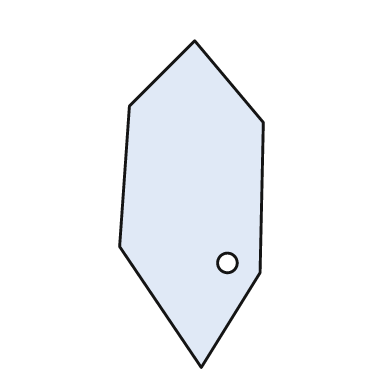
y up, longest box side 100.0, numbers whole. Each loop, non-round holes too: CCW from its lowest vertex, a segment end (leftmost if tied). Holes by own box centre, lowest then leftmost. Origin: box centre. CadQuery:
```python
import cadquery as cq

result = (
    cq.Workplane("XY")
    .moveTo(3.0, -50.0)
    .lineTo(21.0, -21.0)
    .lineTo(22.0, 25.0)
    .lineTo(1.0, 50.0)
    .lineTo(-19.0, 30.0)
    .lineTo(-22.0, -13.0)
    .close()
    .moveTo(11.0, -18.0)
    .circle(3.0)
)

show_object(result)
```